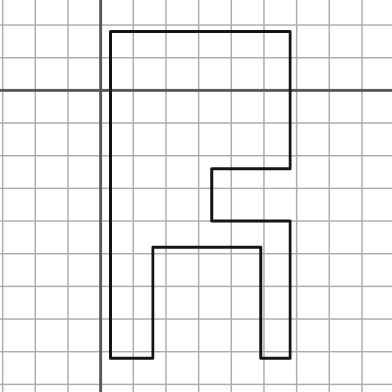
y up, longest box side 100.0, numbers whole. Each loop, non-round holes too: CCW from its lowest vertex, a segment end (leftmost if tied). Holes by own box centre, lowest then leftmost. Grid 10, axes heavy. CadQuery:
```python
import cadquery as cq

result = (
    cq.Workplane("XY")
    .moveTo(3.0, -82.0)
    .lineTo(16.0, -82.0)
    .lineTo(16.0, -48.0)
    .lineTo(49.0, -48.0)
    .lineTo(49.0, -82.0)
    .lineTo(58.0, -82.0)
    .lineTo(58.0, -40.0)
    .lineTo(34.0, -40.0)
    .lineTo(34.0, -24.0)
    .lineTo(58.0, -24.0)
    .lineTo(58.0, 18.0)
    .lineTo(3.0, 18.0)
    .close()
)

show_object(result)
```